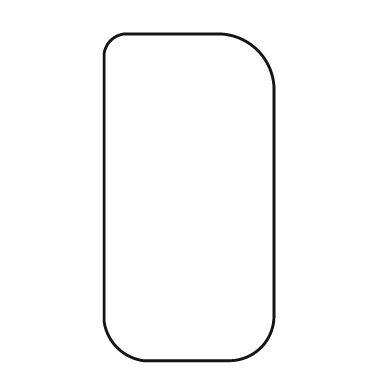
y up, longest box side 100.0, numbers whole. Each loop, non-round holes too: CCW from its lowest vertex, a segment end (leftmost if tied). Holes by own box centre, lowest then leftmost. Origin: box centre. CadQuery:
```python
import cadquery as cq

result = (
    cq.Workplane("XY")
    .moveTo(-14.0, -50.0)
    .lineTo(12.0, -50.0)
    .threePointArc((22.0, -46.0), (26.0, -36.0))
    .lineTo(26.0, 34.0)
    .threePointArc((21.0, 45.0), (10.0, 50.0))
    .lineTo(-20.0, 50.0)
    .threePointArc((-24.0, 48.0), (-26.0, 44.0))
    .lineTo(-26.0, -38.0)
    .threePointArc((-22.0, -46.0), (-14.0, -50.0))
    .close()
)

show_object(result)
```